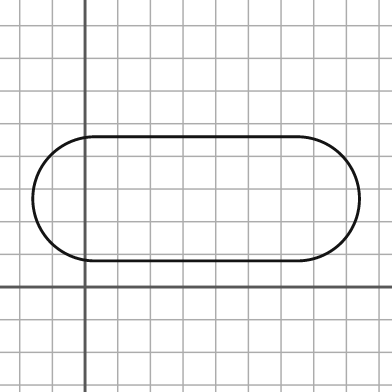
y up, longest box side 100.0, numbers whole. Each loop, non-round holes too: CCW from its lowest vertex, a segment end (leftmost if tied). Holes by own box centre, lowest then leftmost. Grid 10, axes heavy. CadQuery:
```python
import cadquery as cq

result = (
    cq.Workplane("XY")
    .moveTo(3.0, 8.0)
    .lineTo(65.0, 8.0)
    .threePointArc((84.0, 27.0), (65.0, 46.0))
    .lineTo(3.0, 46.0)
    .threePointArc((-16.0, 27.0), (3.0, 8.0))
    .close()
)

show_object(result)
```